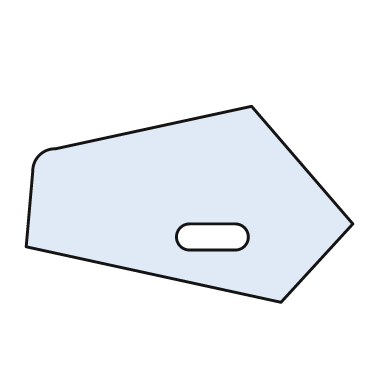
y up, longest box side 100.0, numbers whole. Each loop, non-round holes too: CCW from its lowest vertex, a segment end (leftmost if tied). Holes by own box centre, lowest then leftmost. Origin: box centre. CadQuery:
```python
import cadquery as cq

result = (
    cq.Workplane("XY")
    .moveTo(28.0, -30.0)
    .lineTo(50.0, -6.0)
    .lineTo(19.0, 30.0)
    .lineTo(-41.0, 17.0)
    .threePointArc((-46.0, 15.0), (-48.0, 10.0))
    .lineTo(-50.0, -13.0)
    .close()
    .moveTo(0.0, -14.0)
    .lineTo(14.0, -14.0)
    .threePointArc((18.0, -10.0), (14.0, -6.0))
    .lineTo(0.0, -6.0)
    .threePointArc((-4.0, -10.0), (0.0, -14.0))
    .close()
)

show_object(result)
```